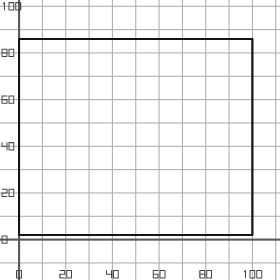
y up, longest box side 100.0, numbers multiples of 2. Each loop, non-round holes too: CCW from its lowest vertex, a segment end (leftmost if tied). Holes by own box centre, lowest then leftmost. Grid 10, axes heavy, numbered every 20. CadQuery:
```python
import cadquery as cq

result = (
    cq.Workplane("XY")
    .moveTo(0.0, 2.0)
    .lineTo(100.0, 2.0)
    .lineTo(100.0, 86.0)
    .lineTo(0.0, 86.0)
    .close()
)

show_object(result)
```